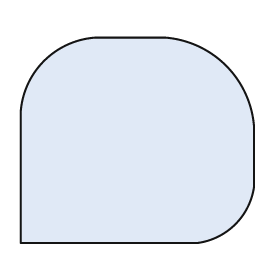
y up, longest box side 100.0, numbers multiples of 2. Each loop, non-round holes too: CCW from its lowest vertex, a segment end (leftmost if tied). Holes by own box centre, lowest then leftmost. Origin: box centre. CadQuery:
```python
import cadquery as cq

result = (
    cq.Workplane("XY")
    .moveTo(-50.0, -44.0)
    .lineTo(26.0, -44.0)
    .threePointArc((42.0, -36.0), (50.0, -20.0))
    .lineTo(50.0, 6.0)
    .threePointArc((38.0, 32.0), (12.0, 44.0))
    .lineTo(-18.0, 44.0)
    .threePointArc((-40.0, 34.0), (-50.0, 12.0))
    .close()
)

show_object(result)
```